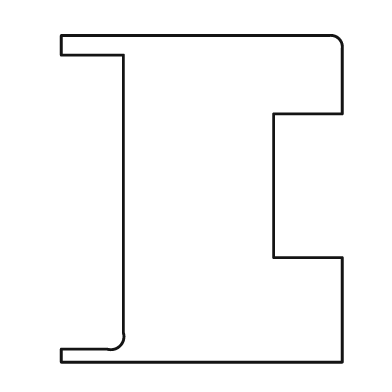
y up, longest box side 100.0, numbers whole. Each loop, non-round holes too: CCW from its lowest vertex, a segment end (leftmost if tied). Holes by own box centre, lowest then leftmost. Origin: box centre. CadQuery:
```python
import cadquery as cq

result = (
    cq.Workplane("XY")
    .moveTo(-43.0, -50.0)
    .lineTo(43.0, -50.0)
    .lineTo(43.0, -18.0)
    .lineTo(22.0, -18.0)
    .lineTo(22.0, 26.0)
    .lineTo(43.0, 26.0)
    .lineTo(43.0, 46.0)
    .threePointArc((42.0, 49.0), (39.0, 50.0))
    .lineTo(-43.0, 50.0)
    .lineTo(-43.0, 44.0)
    .lineTo(-24.0, 44.0)
    .lineTo(-24.0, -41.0)
    .threePointArc((-25.0, -45.0), (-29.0, -46.0))
    .lineTo(-43.0, -46.0)
    .close()
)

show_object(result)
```